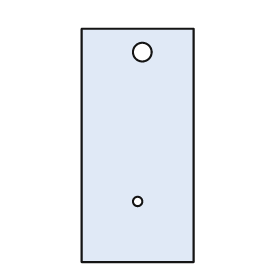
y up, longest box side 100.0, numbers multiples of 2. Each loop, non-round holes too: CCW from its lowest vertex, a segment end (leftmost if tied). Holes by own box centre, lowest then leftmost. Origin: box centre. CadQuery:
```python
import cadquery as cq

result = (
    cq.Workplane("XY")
    .moveTo(-24.0, -50.0)
    .lineTo(24.0, -50.0)
    .lineTo(24.0, 50.0)
    .lineTo(-24.0, 50.0)
    .close()
    .moveTo(0.0, -24.0)
    .circle(2.0)
    .moveTo(2.0, 40.0)
    .circle(4.0)
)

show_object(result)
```